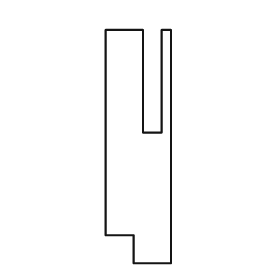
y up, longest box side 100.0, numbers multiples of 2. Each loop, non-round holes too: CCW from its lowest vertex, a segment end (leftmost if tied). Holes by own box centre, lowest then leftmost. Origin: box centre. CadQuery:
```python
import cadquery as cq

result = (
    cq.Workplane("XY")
    .moveTo(-2.0, -50.0)
    .lineTo(14.0, -50.0)
    .lineTo(14.0, 50.0)
    .lineTo(10.0, 50.0)
    .lineTo(10.0, 6.0)
    .lineTo(2.0, 6.0)
    .lineTo(2.0, 50.0)
    .lineTo(-14.0, 50.0)
    .lineTo(-14.0, -38.0)
    .lineTo(-2.0, -38.0)
    .close()
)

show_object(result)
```